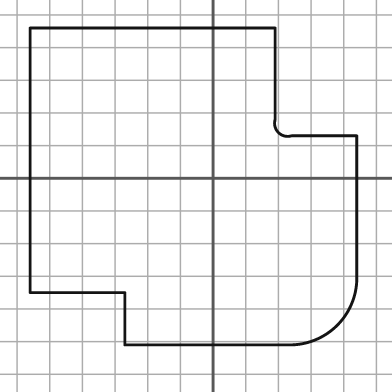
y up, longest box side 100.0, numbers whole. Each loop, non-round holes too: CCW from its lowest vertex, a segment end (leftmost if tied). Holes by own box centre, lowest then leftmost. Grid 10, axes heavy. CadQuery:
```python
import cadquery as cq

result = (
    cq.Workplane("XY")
    .moveTo(-27.0, -51.0)
    .lineTo(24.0, -51.0)
    .threePointArc((38.0, -45.0), (44.0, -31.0))
    .lineTo(44.0, 13.0)
    .lineTo(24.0, 13.0)
    .threePointArc((20.0, 14.0), (19.0, 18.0))
    .lineTo(19.0, 46.0)
    .lineTo(-56.0, 46.0)
    .lineTo(-56.0, -35.0)
    .lineTo(-27.0, -35.0)
    .close()
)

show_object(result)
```